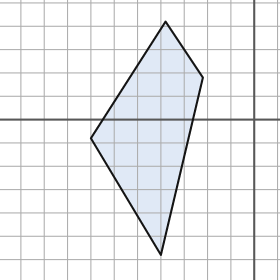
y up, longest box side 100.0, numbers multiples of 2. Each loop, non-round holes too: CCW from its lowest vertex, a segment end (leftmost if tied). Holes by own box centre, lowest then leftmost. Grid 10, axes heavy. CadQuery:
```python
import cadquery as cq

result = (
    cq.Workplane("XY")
    .moveTo(-40.0, -58.0)
    .lineTo(-22.0, 18.0)
    .lineTo(-38.0, 42.0)
    .lineTo(-70.0, -8.0)
    .close()
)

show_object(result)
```